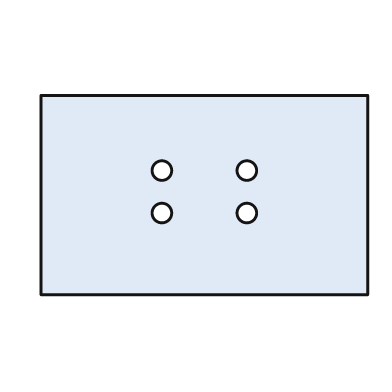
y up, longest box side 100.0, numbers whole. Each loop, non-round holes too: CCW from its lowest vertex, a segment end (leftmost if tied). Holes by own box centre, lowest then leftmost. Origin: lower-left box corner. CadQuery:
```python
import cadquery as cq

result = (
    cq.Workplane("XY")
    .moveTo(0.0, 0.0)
    .lineTo(100.0, 0.0)
    .lineTo(100.0, 61.0)
    .lineTo(0.0, 61.0)
    .close()
    .moveTo(37.0, 25.0)
    .circle(3.0)
    .moveTo(63.0, 25.0)
    .circle(3.0)
    .moveTo(37.0, 38.0)
    .circle(3.0)
    .moveTo(63.0, 38.0)
    .circle(3.0)
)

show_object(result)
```